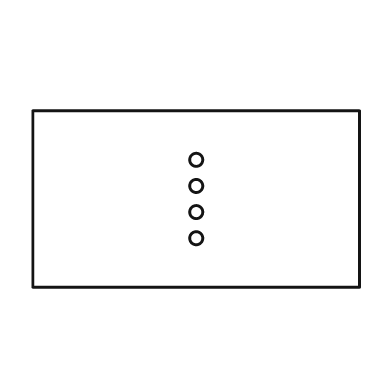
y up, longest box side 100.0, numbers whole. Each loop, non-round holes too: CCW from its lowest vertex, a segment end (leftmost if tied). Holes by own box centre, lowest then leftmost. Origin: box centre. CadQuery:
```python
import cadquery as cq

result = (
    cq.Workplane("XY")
    .moveTo(-50.0, -27.0)
    .lineTo(50.0, -27.0)
    .lineTo(50.0, 27.0)
    .lineTo(-50.0, 27.0)
    .close()
    .moveTo(0.0, -12.0)
    .circle(2.0)
    .moveTo(0.0, -4.0)
    .circle(2.0)
    .moveTo(0.0, 4.0)
    .circle(2.0)
    .moveTo(0.0, 12.0)
    .circle(2.0)
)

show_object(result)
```